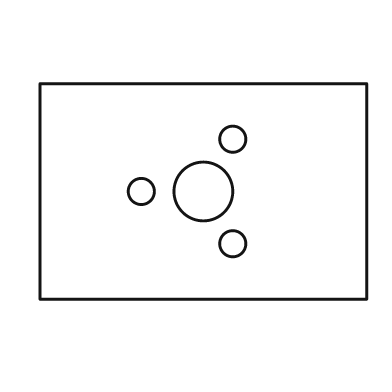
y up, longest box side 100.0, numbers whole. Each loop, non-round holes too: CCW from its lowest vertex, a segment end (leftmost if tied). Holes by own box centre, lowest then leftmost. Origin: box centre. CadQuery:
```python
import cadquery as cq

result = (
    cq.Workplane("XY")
    .moveTo(-50.0, -33.0)
    .lineTo(50.0, -33.0)
    .lineTo(50.0, 33.0)
    .lineTo(-50.0, 33.0)
    .close()
    .moveTo(9.0, -16.0)
    .circle(4.0)
    .moveTo(-19.0, 0.0)
    .circle(4.0)
    .moveTo(0.0, 0.0)
    .circle(9.0)
    .moveTo(9.0, 16.0)
    .circle(4.0)
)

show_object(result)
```